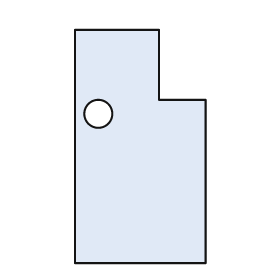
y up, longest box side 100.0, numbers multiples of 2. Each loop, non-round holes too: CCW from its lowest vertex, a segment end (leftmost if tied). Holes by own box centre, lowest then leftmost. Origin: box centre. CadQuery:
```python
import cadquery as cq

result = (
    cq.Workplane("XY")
    .moveTo(-28.0, -50.0)
    .lineTo(28.0, -50.0)
    .lineTo(28.0, 20.0)
    .lineTo(8.0, 20.0)
    .lineTo(8.0, 50.0)
    .lineTo(-28.0, 50.0)
    .close()
    .moveTo(-18.0, 14.0)
    .circle(6.0)
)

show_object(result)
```